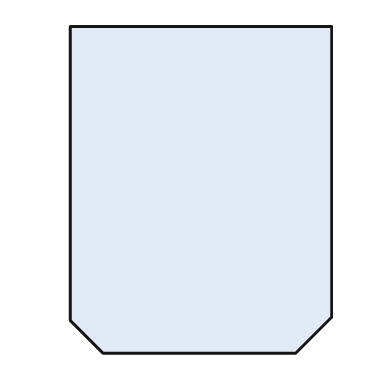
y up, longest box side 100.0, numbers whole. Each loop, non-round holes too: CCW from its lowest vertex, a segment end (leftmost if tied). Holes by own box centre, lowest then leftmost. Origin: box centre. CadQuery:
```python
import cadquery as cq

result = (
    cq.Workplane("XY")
    .moveTo(-30.0, -50.0)
    .lineTo(29.0, -50.0)
    .lineTo(40.0, -39.0)
    .lineTo(40.0, 50.0)
    .lineTo(-40.0, 50.0)
    .lineTo(-40.0, -40.0)
    .close()
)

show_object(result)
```